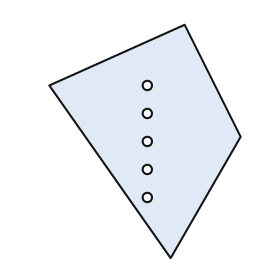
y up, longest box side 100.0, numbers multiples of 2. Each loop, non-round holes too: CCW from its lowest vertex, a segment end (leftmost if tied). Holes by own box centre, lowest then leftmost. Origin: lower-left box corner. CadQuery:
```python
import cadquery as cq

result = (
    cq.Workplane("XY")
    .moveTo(52.0, 0.0)
    .lineTo(82.0, 52.0)
    .lineTo(58.0, 100.0)
    .lineTo(0.0, 74.0)
    .close()
    .moveTo(42.0, 26.0)
    .circle(2.0)
    .moveTo(42.0, 38.0)
    .circle(2.0)
    .moveTo(42.0, 50.0)
    .circle(2.0)
    .moveTo(42.0, 62.0)
    .circle(2.0)
    .moveTo(42.0, 74.0)
    .circle(2.0)
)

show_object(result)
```